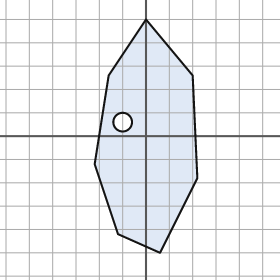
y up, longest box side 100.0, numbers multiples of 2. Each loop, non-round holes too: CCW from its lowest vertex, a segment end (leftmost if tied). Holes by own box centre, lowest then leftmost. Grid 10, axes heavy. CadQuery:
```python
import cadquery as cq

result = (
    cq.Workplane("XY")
    .moveTo(6.0, -50.0)
    .lineTo(22.0, -18.0)
    .lineTo(20.0, 26.0)
    .lineTo(0.0, 50.0)
    .lineTo(-16.0, 26.0)
    .lineTo(-22.0, -12.0)
    .lineTo(-12.0, -42.0)
    .close()
    .moveTo(-10.0, 6.0)
    .circle(4.0)
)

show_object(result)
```